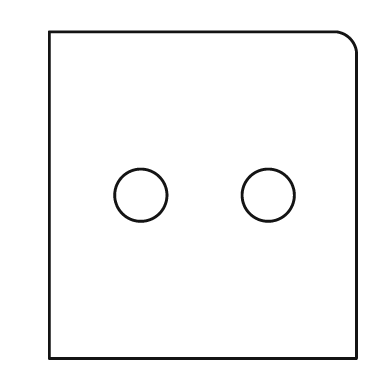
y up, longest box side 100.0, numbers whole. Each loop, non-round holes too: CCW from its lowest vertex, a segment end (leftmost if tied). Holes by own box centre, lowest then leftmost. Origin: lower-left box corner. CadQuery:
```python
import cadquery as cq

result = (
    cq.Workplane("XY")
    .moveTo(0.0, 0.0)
    .lineTo(94.0, 0.0)
    .lineTo(94.0, 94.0)
    .threePointArc((92.0, 98.0), (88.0, 100.0))
    .lineTo(0.0, 100.0)
    .close()
    .moveTo(28.0, 50.0)
    .circle(8.0)
    .moveTo(67.0, 50.0)
    .circle(8.0)
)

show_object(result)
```